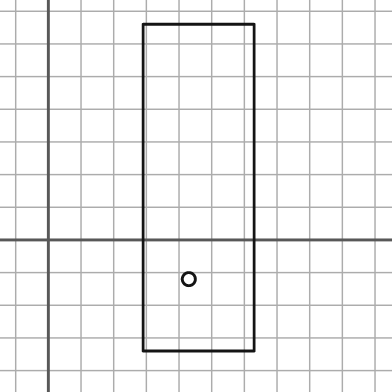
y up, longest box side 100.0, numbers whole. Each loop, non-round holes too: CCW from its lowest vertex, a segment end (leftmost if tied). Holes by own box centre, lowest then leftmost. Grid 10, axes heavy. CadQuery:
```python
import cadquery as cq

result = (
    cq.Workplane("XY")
    .moveTo(29.0, -34.0)
    .lineTo(63.0, -34.0)
    .lineTo(63.0, 66.0)
    .lineTo(29.0, 66.0)
    .close()
    .moveTo(43.0, -12.0)
    .circle(2.0)
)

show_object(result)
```